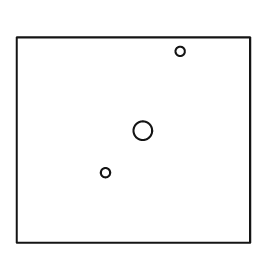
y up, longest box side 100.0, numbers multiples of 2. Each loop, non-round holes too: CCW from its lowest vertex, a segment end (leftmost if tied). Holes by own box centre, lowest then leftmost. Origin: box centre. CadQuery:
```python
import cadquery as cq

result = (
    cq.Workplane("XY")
    .moveTo(-50.0, -44.0)
    .lineTo(50.0, -44.0)
    .lineTo(50.0, 44.0)
    .lineTo(-50.0, 44.0)
    .close()
    .moveTo(-12.0, -14.0)
    .circle(2.0)
    .moveTo(4.0, 4.0)
    .circle(4.0)
    .moveTo(20.0, 38.0)
    .circle(2.0)
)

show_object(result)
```